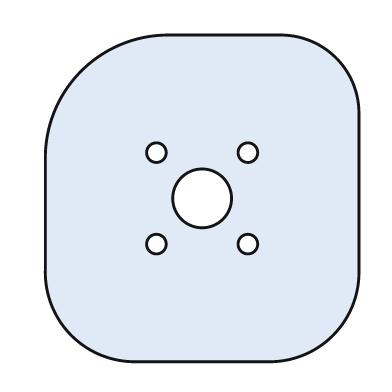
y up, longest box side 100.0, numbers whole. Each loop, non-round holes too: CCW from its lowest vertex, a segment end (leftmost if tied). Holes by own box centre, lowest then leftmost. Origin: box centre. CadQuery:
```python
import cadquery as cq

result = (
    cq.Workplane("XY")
    .moveTo(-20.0, -50.0)
    .lineTo(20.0, -50.0)
    .threePointArc((40.0, -42.0), (48.0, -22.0))
    .lineTo(48.0, 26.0)
    .threePointArc((41.0, 43.0), (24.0, 50.0))
    .lineTo(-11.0, 50.0)
    .threePointArc((-37.0, 39.0), (-48.0, 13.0))
    .lineTo(-48.0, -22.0)
    .threePointArc((-40.0, -42.0), (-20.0, -50.0))
    .close()
    .moveTo(-14.0, -14.0)
    .circle(3.0)
    .moveTo(14.0, -14.0)
    .circle(3.0)
    .moveTo(0.0, 0.0)
    .circle(9.0)
    .moveTo(-14.0, 14.0)
    .circle(3.0)
    .moveTo(14.0, 14.0)
    .circle(3.0)
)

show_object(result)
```